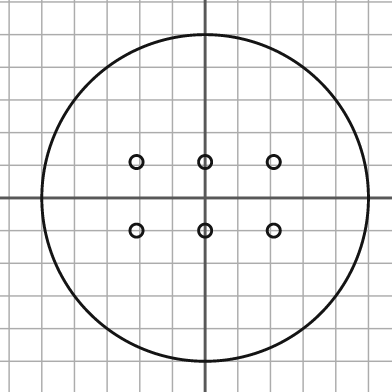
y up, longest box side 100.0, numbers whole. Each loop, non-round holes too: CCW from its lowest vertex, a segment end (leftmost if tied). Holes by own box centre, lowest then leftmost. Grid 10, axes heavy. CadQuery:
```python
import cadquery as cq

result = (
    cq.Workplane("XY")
    .moveTo(0.0, 0.0)
    .circle(50.0)
    .moveTo(-21.0, -10.0)
    .circle(2.0)
    .moveTo(0.0, -10.0)
    .circle(2.0)
    .moveTo(21.0, -10.0)
    .circle(2.0)
    .moveTo(-21.0, 11.0)
    .circle(2.0)
    .moveTo(0.0, 11.0)
    .circle(2.0)
    .moveTo(21.0, 11.0)
    .circle(2.0)
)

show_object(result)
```